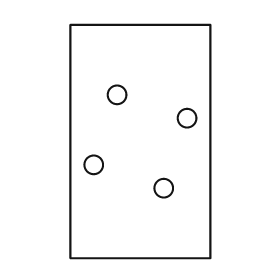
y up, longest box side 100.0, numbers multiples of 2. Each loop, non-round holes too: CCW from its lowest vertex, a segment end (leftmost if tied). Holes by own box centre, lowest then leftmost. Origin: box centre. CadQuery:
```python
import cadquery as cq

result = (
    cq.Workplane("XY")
    .moveTo(-30.0, -50.0)
    .lineTo(30.0, -50.0)
    .lineTo(30.0, 50.0)
    .lineTo(-30.0, 50.0)
    .close()
    .moveTo(10.0, -20.0)
    .circle(4.0)
    .moveTo(-20.0, -10.0)
    .circle(4.0)
    .moveTo(20.0, 10.0)
    .circle(4.0)
    .moveTo(-10.0, 20.0)
    .circle(4.0)
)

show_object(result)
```